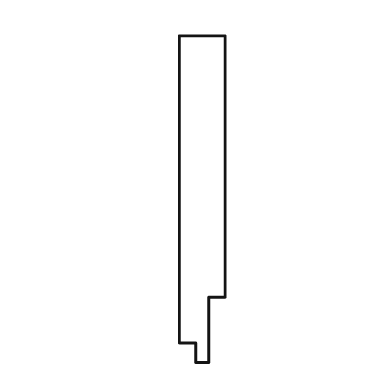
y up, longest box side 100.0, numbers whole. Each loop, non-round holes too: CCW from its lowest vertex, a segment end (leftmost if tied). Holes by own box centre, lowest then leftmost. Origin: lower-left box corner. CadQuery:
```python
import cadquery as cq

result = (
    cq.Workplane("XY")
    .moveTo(5.0, 0.0)
    .lineTo(9.0, 0.0)
    .lineTo(9.0, 20.0)
    .lineTo(14.0, 20.0)
    .lineTo(14.0, 100.0)
    .lineTo(0.0, 100.0)
    .lineTo(0.0, 6.0)
    .lineTo(5.0, 6.0)
    .close()
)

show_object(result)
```